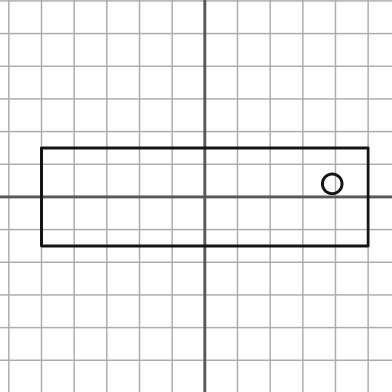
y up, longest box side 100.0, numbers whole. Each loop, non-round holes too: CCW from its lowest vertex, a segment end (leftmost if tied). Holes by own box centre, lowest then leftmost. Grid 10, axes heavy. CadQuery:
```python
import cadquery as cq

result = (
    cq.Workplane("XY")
    .moveTo(-50.0, -15.0)
    .lineTo(50.0, -15.0)
    .lineTo(50.0, 15.0)
    .lineTo(-50.0, 15.0)
    .close()
    .moveTo(39.0, 4.0)
    .circle(3.0)
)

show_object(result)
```